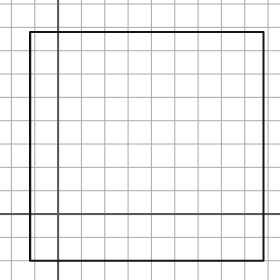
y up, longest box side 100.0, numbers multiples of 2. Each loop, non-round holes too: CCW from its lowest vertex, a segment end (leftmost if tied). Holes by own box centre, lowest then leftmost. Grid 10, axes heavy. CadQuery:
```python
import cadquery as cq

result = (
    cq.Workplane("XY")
    .moveTo(-12.0, -20.0)
    .lineTo(88.0, -20.0)
    .lineTo(88.0, 78.0)
    .lineTo(-12.0, 78.0)
    .close()
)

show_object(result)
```